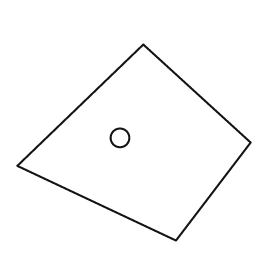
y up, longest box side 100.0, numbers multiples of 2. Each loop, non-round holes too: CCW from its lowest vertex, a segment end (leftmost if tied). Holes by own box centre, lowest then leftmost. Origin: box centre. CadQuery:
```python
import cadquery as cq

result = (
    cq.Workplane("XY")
    .moveTo(18.0, -42.0)
    .lineTo(50.0, 0.0)
    .lineTo(4.0, 42.0)
    .lineTo(-50.0, -10.0)
    .close()
    .moveTo(-6.0, 2.0)
    .circle(4.0)
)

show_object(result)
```